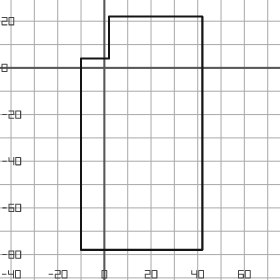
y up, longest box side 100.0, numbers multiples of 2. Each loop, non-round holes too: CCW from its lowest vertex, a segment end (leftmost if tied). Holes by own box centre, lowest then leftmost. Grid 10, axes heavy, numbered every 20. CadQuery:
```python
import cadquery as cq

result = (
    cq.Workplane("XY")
    .moveTo(-10.0, -78.0)
    .lineTo(42.0, -78.0)
    .lineTo(42.0, 22.0)
    .lineTo(2.0, 22.0)
    .lineTo(2.0, 4.0)
    .lineTo(-10.0, 4.0)
    .close()
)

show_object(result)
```